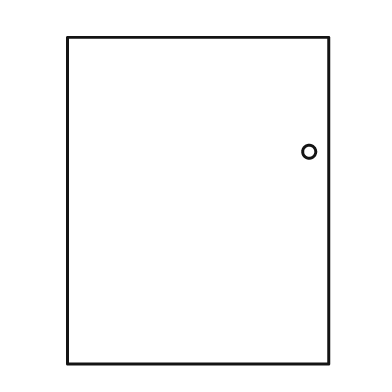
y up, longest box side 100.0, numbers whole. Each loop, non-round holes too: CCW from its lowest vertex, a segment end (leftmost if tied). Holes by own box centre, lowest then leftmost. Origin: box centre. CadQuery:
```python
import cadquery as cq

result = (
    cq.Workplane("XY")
    .moveTo(-40.0, -50.0)
    .lineTo(40.0, -50.0)
    .lineTo(40.0, 50.0)
    .lineTo(-40.0, 50.0)
    .close()
    .moveTo(34.0, 15.0)
    .circle(2.0)
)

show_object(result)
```